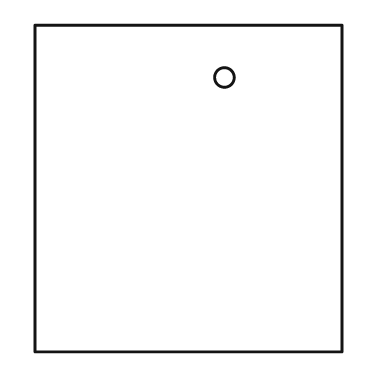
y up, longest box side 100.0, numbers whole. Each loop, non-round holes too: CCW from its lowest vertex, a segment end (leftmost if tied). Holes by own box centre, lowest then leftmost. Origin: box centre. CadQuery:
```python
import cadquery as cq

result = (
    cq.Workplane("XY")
    .moveTo(-47.0, -50.0)
    .lineTo(47.0, -50.0)
    .lineTo(47.0, 50.0)
    .lineTo(-47.0, 50.0)
    .close()
    .moveTo(11.0, 34.0)
    .circle(3.0)
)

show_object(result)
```